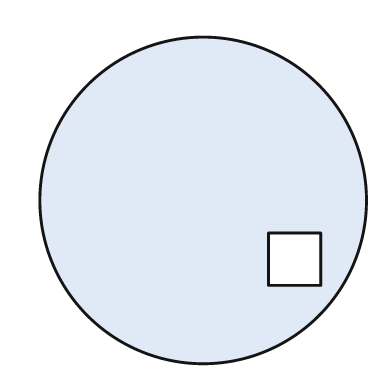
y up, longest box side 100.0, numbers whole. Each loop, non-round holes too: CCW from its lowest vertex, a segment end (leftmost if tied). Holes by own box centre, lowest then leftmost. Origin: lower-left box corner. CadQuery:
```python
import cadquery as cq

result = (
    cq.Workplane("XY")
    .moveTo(50.0, 50.0)
    .circle(50.0)
    .moveTo(70.0, 24.0)
    .lineTo(86.0, 24.0)
    .lineTo(86.0, 40.0)
    .lineTo(70.0, 40.0)
    .close()
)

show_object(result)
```